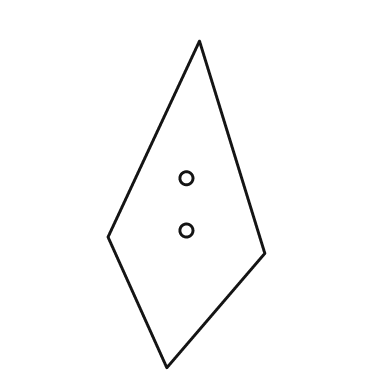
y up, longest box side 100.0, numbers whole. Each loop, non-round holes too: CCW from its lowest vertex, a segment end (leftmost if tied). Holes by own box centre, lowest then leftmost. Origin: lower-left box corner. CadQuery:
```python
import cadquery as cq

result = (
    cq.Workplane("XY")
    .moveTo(18.0, 0.0)
    .lineTo(48.0, 35.0)
    .lineTo(28.0, 100.0)
    .lineTo(0.0, 40.0)
    .close()
    .moveTo(24.0, 42.0)
    .circle(2.0)
    .moveTo(24.0, 58.0)
    .circle(2.0)
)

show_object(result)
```